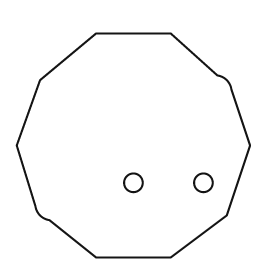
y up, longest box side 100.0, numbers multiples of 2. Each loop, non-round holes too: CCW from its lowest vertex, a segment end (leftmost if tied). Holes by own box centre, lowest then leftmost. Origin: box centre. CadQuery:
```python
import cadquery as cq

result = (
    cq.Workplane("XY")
    .moveTo(-16.0, -48.0)
    .lineTo(16.0, -48.0)
    .lineTo(40.0, -30.0)
    .lineTo(50.0, 0.0)
    .lineTo(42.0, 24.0)
    .threePointArc((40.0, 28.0), (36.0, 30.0))
    .lineTo(16.0, 48.0)
    .lineTo(-16.0, 48.0)
    .lineTo(-40.0, 28.0)
    .lineTo(-50.0, 0.0)
    .lineTo(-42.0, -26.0)
    .threePointArc((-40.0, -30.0), (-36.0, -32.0))
    .close()
    .moveTo(0.0, -16.0)
    .circle(4.0)
    .moveTo(30.0, -16.0)
    .circle(4.0)
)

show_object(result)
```